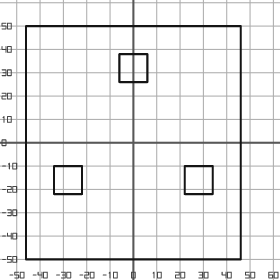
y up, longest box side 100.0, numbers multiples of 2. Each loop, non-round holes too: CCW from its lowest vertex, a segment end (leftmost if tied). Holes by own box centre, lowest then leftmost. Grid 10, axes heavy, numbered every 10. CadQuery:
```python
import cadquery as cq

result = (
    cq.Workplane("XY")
    .moveTo(-46.0, -50.0)
    .lineTo(46.0, -50.0)
    .lineTo(46.0, 50.0)
    .lineTo(-46.0, 50.0)
    .close()
    .moveTo(-34.0, -22.0)
    .lineTo(-22.0, -22.0)
    .lineTo(-22.0, -10.0)
    .lineTo(-34.0, -10.0)
    .close()
    .moveTo(22.0, -22.0)
    .lineTo(34.0, -22.0)
    .lineTo(34.0, -10.0)
    .lineTo(22.0, -10.0)
    .close()
    .moveTo(-6.0, 26.0)
    .lineTo(6.0, 26.0)
    .lineTo(6.0, 38.0)
    .lineTo(-6.0, 38.0)
    .close()
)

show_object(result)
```